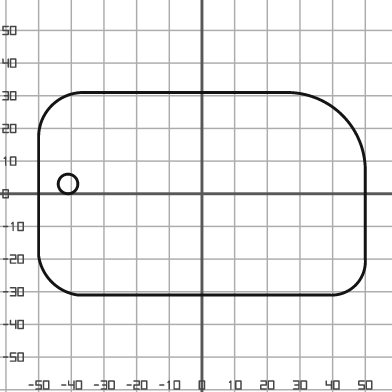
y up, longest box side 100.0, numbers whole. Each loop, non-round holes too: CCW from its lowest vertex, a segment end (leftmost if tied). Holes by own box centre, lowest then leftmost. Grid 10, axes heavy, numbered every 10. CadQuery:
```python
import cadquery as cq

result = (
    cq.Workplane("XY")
    .moveTo(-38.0, -31.0)
    .lineTo(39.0, -31.0)
    .threePointArc((47.0, -28.0), (50.0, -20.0))
    .lineTo(50.0, 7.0)
    .threePointArc((43.0, 24.0), (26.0, 31.0))
    .lineTo(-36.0, 31.0)
    .threePointArc((-46.0, 27.0), (-50.0, 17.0))
    .lineTo(-50.0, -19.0)
    .threePointArc((-46.0, -27.0), (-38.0, -31.0))
    .close()
    .moveTo(-41.0, 3.0)
    .circle(3.0)
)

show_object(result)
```